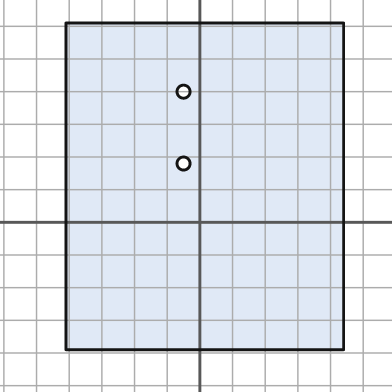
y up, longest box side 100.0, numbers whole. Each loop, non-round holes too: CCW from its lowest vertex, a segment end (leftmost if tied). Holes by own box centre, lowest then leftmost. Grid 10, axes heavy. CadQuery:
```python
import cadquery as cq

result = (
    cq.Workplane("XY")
    .moveTo(-41.0, -39.0)
    .lineTo(44.0, -39.0)
    .lineTo(44.0, 61.0)
    .lineTo(-41.0, 61.0)
    .close()
    .moveTo(-5.0, 18.0)
    .circle(2.0)
    .moveTo(-5.0, 40.0)
    .circle(2.0)
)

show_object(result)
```